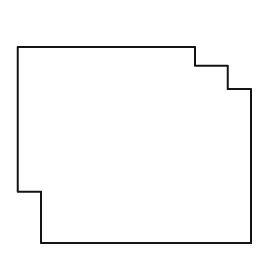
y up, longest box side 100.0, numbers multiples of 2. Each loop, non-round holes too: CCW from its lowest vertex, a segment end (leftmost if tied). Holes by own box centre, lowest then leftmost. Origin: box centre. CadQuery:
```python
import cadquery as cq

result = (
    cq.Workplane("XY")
    .moveTo(-40.0, -42.0)
    .lineTo(50.0, -42.0)
    .lineTo(50.0, 24.0)
    .lineTo(40.0, 24.0)
    .lineTo(40.0, 34.0)
    .lineTo(26.0, 34.0)
    .lineTo(26.0, 42.0)
    .lineTo(-50.0, 42.0)
    .lineTo(-50.0, -20.0)
    .lineTo(-40.0, -20.0)
    .close()
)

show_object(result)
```